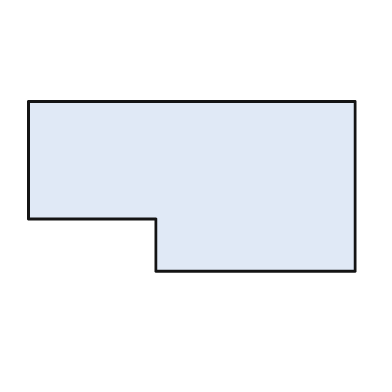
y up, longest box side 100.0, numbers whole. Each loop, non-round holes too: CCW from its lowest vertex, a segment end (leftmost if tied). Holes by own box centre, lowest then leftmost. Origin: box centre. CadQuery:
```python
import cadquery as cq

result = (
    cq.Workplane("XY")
    .moveTo(-11.0, -26.0)
    .lineTo(50.0, -26.0)
    .lineTo(50.0, 26.0)
    .lineTo(-50.0, 26.0)
    .lineTo(-50.0, -10.0)
    .lineTo(-11.0, -10.0)
    .close()
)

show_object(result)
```